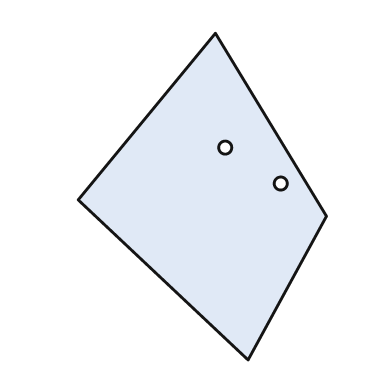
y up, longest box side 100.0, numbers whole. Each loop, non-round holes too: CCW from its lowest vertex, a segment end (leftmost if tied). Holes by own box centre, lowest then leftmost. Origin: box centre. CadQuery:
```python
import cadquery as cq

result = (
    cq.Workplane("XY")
    .moveTo(14.0, -50.0)
    .lineTo(38.0, -6.0)
    .lineTo(4.0, 50.0)
    .lineTo(-38.0, -1.0)
    .close()
    .moveTo(24.0, 4.0)
    .circle(2.0)
    .moveTo(7.0, 15.0)
    .circle(2.0)
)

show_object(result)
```